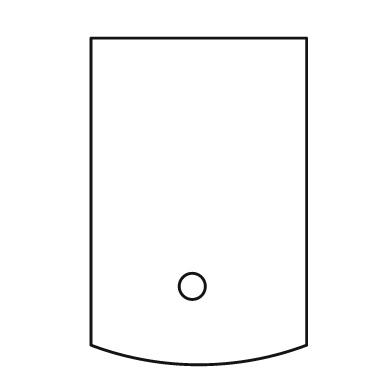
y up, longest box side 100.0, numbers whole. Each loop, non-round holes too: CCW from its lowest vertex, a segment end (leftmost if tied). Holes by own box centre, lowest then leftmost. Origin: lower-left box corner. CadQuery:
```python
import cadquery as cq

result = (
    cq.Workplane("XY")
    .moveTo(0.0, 6.0)
    .threePointArc((33.0, 0.0), (66.0, 6.0))
    .lineTo(66.0, 100.0)
    .lineTo(0.0, 100.0)
    .close()
    .moveTo(31.0, 24.0)
    .circle(4.0)
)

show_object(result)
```